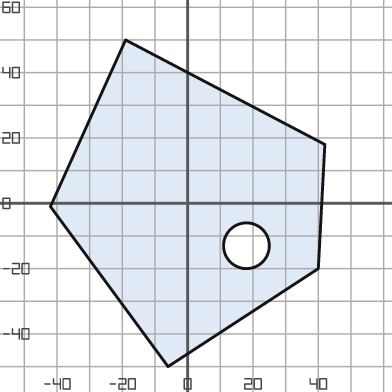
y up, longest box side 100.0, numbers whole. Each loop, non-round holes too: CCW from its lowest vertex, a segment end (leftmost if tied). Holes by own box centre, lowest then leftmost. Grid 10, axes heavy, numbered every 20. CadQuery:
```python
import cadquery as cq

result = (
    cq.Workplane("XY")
    .moveTo(-6.0, -50.0)
    .lineTo(40.0, -20.0)
    .lineTo(42.0, 18.0)
    .lineTo(-19.0, 50.0)
    .lineTo(-42.0, -1.0)
    .close()
    .moveTo(18.0, -13.0)
    .circle(7.0)
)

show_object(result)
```